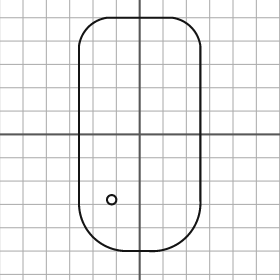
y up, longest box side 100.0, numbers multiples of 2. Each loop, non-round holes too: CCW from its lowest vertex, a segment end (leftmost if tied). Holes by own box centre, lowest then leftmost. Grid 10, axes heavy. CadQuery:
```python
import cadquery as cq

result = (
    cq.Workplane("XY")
    .moveTo(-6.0, -50.0)
    .lineTo(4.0, -50.0)
    .threePointArc((20.0, -44.0), (26.0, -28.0))
    .lineTo(26.0, 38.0)
    .threePointArc((22.0, 46.0), (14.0, 50.0))
    .lineTo(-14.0, 50.0)
    .threePointArc((-22.0, 46.0), (-26.0, 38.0))
    .lineTo(-26.0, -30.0)
    .threePointArc((-20.0, -44.0), (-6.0, -50.0))
    .close()
    .moveTo(-12.0, -28.0)
    .circle(2.0)
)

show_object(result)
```